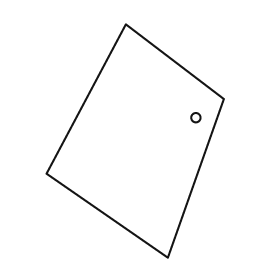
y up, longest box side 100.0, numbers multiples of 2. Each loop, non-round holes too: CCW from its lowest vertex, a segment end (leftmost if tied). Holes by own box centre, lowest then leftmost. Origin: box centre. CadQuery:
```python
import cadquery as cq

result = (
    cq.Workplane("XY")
    .moveTo(14.0, -50.0)
    .lineTo(38.0, 18.0)
    .lineTo(-4.0, 50.0)
    .lineTo(-38.0, -14.0)
    .close()
    .moveTo(26.0, 10.0)
    .circle(2.0)
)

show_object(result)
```